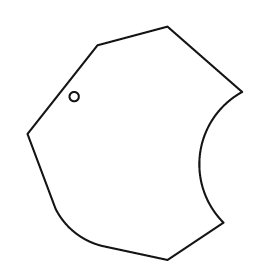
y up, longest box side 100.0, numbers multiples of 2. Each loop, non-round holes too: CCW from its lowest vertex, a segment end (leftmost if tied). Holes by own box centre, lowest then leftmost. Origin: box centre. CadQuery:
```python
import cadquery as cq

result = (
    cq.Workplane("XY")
    .moveTo(14.0, -50.0)
    .lineTo(38.0, -34.0)
    .threePointArc((28.0, -4.0), (46.0, 22.0))
    .lineTo(14.0, 50.0)
    .lineTo(-16.0, 42.0)
    .lineTo(-46.0, 4.0)
    .lineTo(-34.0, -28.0)
    .threePointArc((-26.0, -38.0), (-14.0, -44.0))
    .close()
    .moveTo(-26.0, 20.0)
    .circle(2.0)
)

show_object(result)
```